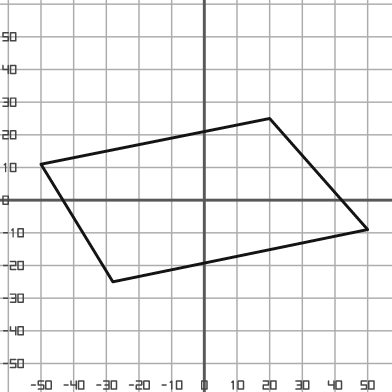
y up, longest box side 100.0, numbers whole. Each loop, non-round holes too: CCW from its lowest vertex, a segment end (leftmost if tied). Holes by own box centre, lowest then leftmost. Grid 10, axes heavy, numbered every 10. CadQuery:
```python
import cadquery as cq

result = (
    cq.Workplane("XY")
    .moveTo(-28.0, -25.0)
    .lineTo(50.0, -9.0)
    .lineTo(20.0, 25.0)
    .lineTo(-50.0, 11.0)
    .close()
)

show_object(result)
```